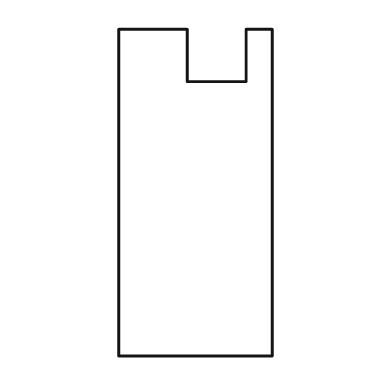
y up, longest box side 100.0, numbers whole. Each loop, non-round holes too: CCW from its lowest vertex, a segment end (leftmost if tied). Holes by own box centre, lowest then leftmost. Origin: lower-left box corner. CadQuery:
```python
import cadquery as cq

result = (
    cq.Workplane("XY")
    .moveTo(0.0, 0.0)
    .lineTo(47.0, 0.0)
    .lineTo(47.0, 100.0)
    .lineTo(39.0, 100.0)
    .lineTo(39.0, 84.0)
    .lineTo(21.0, 84.0)
    .lineTo(21.0, 100.0)
    .lineTo(0.0, 100.0)
    .close()
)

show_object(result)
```